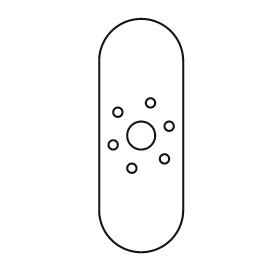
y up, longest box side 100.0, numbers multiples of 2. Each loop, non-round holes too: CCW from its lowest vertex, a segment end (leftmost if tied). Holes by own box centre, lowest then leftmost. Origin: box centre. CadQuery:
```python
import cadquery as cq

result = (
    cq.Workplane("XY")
    .moveTo(-18.0, -32.0)
    .threePointArc((0.0, -50.0), (18.0, -32.0))
    .lineTo(18.0, 32.0)
    .threePointArc((0.0, 50.0), (-18.0, 32.0))
    .close()
    .moveTo(-4.0, -14.0)
    .circle(2.0)
    .moveTo(10.0, -10.0)
    .circle(2.0)
    .moveTo(-12.0, -4.0)
    .circle(2.0)
    .moveTo(0.0, 0.0)
    .circle(6.0)
    .moveTo(12.0, 4.0)
    .circle(2.0)
    .moveTo(-10.0, 10.0)
    .circle(2.0)
    .moveTo(4.0, 14.0)
    .circle(2.0)
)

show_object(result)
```